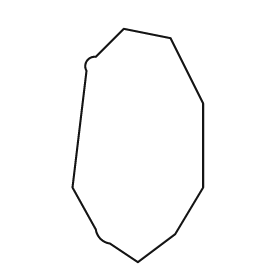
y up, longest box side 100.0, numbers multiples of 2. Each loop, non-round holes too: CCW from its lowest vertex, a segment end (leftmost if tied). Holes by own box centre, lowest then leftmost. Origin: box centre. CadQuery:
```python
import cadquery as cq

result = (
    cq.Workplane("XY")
    .moveTo(0.0, -50.0)
    .lineTo(16.0, -38.0)
    .lineTo(28.0, -18.0)
    .lineTo(28.0, 18.0)
    .lineTo(14.0, 46.0)
    .lineTo(-6.0, 50.0)
    .lineTo(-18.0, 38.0)
    .threePointArc((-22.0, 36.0), (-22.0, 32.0))
    .lineTo(-28.0, -18.0)
    .lineTo(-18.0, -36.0)
    .threePointArc((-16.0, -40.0), (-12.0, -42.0))
    .close()
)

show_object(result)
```